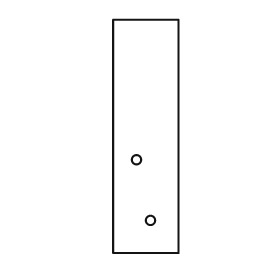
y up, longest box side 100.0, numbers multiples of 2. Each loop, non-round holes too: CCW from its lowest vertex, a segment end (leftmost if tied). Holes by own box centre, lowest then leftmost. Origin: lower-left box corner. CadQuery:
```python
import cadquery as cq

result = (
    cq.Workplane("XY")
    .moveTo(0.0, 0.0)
    .lineTo(28.0, 0.0)
    .lineTo(28.0, 100.0)
    .lineTo(0.0, 100.0)
    .close()
    .moveTo(16.0, 14.0)
    .circle(2.0)
    .moveTo(10.0, 40.0)
    .circle(2.0)
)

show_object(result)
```